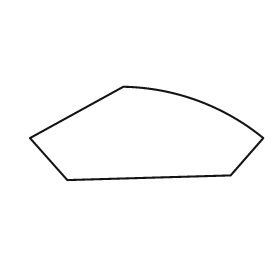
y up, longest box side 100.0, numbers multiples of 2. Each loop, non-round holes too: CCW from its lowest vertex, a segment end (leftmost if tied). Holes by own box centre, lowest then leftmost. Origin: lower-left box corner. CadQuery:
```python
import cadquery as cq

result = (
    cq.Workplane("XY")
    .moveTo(16.0, 0.0)
    .lineTo(86.0, 2.0)
    .lineTo(100.0, 18.0)
    .threePointArc((72.0, 34.0), (40.0, 40.0))
    .lineTo(0.0, 18.0)
    .close()
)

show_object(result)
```